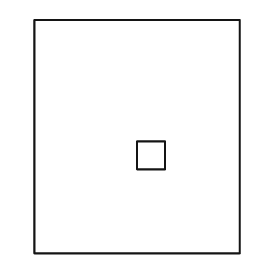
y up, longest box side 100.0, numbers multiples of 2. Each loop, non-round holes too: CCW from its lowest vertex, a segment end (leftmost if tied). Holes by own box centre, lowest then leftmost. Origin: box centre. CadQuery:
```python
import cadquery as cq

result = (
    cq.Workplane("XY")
    .moveTo(-44.0, -50.0)
    .lineTo(44.0, -50.0)
    .lineTo(44.0, 50.0)
    .lineTo(-44.0, 50.0)
    .close()
    .moveTo(0.0, -14.0)
    .lineTo(12.0, -14.0)
    .lineTo(12.0, -2.0)
    .lineTo(0.0, -2.0)
    .close()
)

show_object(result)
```